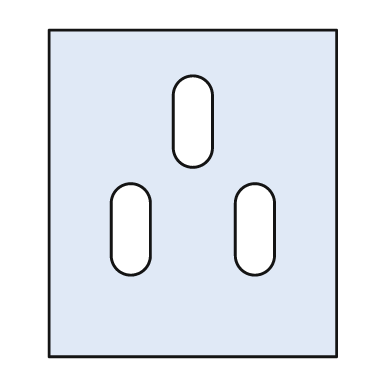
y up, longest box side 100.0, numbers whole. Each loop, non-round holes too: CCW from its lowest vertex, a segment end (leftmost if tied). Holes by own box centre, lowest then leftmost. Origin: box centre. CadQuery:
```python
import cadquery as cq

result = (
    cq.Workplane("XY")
    .moveTo(-44.0, -50.0)
    .lineTo(44.0, -50.0)
    .lineTo(44.0, 50.0)
    .lineTo(-44.0, 50.0)
    .close()
    .moveTo(-25.0, -19.0)
    .threePointArc((-19.0, -25.0), (-13.0, -19.0))
    .lineTo(-13.0, -3.0)
    .threePointArc((-19.0, 3.0), (-25.0, -3.0))
    .close()
    .moveTo(13.0, -19.0)
    .threePointArc((19.0, -25.0), (25.0, -19.0))
    .lineTo(25.0, -3.0)
    .threePointArc((19.0, 3.0), (13.0, -3.0))
    .close()
    .moveTo(-6.0, 14.0)
    .threePointArc((0.0, 8.0), (6.0, 14.0))
    .lineTo(6.0, 30.0)
    .threePointArc((0.0, 36.0), (-6.0, 30.0))
    .close()
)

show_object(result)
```